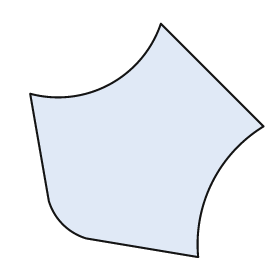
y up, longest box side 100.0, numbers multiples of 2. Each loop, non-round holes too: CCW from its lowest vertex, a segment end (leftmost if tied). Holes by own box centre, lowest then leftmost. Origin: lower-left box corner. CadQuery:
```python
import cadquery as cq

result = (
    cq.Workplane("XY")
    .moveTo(72.0, 0.0)
    .threePointArc((78.0, 32.0), (100.0, 56.0))
    .lineTo(56.0, 100.0)
    .threePointArc((34.0, 74.0), (0.0, 70.0))
    .lineTo(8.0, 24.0)
    .threePointArc((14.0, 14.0), (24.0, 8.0))
    .close()
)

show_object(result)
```